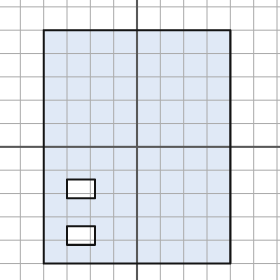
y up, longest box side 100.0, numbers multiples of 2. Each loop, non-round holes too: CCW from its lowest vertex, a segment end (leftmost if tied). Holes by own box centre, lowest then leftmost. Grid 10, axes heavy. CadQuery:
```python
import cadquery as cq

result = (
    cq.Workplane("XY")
    .moveTo(-40.0, -50.0)
    .lineTo(40.0, -50.0)
    .lineTo(40.0, 50.0)
    .lineTo(-40.0, 50.0)
    .close()
    .moveTo(-30.0, -42.0)
    .lineTo(-18.0, -42.0)
    .lineTo(-18.0, -34.0)
    .lineTo(-30.0, -34.0)
    .close()
    .moveTo(-30.0, -22.0)
    .lineTo(-18.0, -22.0)
    .lineTo(-18.0, -14.0)
    .lineTo(-30.0, -14.0)
    .close()
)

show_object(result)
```